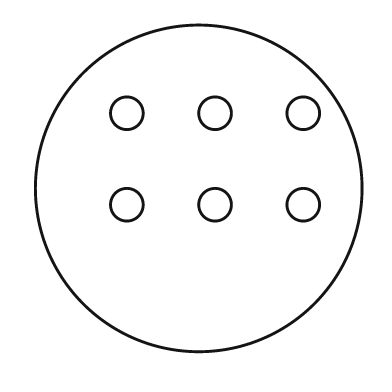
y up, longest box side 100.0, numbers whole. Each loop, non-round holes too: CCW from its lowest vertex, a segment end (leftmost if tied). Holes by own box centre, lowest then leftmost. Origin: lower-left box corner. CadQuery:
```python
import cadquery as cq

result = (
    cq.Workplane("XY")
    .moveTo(50.0, 50.0)
    .circle(50.0)
    .moveTo(28.0, 45.0)
    .circle(5.0)
    .moveTo(55.0, 45.0)
    .circle(5.0)
    .moveTo(82.0, 45.0)
    .circle(5.0)
    .moveTo(28.0, 73.0)
    .circle(5.0)
    .moveTo(55.0, 73.0)
    .circle(5.0)
    .moveTo(82.0, 73.0)
    .circle(5.0)
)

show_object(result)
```